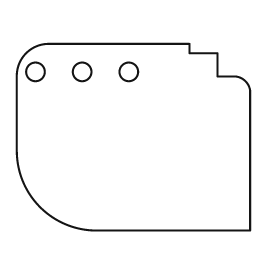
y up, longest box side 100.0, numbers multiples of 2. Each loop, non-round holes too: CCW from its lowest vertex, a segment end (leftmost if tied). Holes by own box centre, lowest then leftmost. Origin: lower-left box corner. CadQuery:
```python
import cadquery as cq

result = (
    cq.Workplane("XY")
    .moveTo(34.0, 0.0)
    .lineTo(100.0, 0.0)
    .lineTo(100.0, 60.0)
    .threePointArc((98.0, 64.0), (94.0, 66.0))
    .lineTo(86.0, 66.0)
    .lineTo(86.0, 76.0)
    .lineTo(74.0, 76.0)
    .lineTo(74.0, 80.0)
    .lineTo(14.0, 80.0)
    .threePointArc((4.0, 76.0), (0.0, 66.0))
    .lineTo(0.0, 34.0)
    .threePointArc((10.0, 10.0), (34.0, 0.0))
    .close()
    .moveTo(8.0, 68.0)
    .circle(4.0)
    .moveTo(28.0, 68.0)
    .circle(4.0)
    .moveTo(48.0, 68.0)
    .circle(4.0)
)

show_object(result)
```